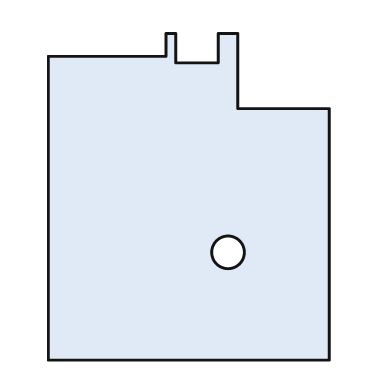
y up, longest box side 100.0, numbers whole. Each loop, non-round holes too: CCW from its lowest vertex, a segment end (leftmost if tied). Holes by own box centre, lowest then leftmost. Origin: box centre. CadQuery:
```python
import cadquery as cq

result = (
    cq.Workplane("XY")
    .moveTo(-43.0, -50.0)
    .lineTo(43.0, -50.0)
    .lineTo(43.0, 27.0)
    .lineTo(15.0, 27.0)
    .lineTo(15.0, 50.0)
    .lineTo(9.0, 50.0)
    .lineTo(9.0, 41.0)
    .lineTo(-4.0, 41.0)
    .lineTo(-4.0, 50.0)
    .lineTo(-7.0, 50.0)
    .lineTo(-7.0, 43.0)
    .lineTo(-43.0, 43.0)
    .close()
    .moveTo(12.0, -17.0)
    .circle(5.0)
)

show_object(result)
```